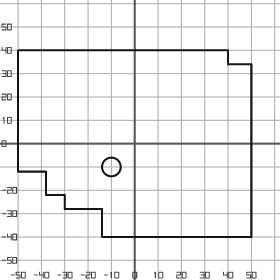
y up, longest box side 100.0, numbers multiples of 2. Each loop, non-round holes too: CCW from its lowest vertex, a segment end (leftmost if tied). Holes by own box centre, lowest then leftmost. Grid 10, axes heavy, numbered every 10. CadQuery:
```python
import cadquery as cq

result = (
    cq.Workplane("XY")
    .moveTo(-14.0, -40.0)
    .lineTo(50.0, -40.0)
    .lineTo(50.0, 34.0)
    .lineTo(40.0, 34.0)
    .lineTo(40.0, 40.0)
    .lineTo(-50.0, 40.0)
    .lineTo(-50.0, -12.0)
    .lineTo(-38.0, -12.0)
    .lineTo(-38.0, -22.0)
    .lineTo(-30.0, -22.0)
    .lineTo(-30.0, -28.0)
    .lineTo(-14.0, -28.0)
    .close()
    .moveTo(-10.0, -10.0)
    .circle(4.0)
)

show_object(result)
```